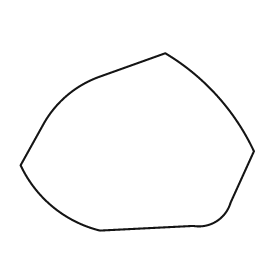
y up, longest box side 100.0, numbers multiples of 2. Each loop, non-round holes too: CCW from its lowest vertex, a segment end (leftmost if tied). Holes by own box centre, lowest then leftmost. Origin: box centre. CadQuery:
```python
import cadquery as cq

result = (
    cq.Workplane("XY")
    .moveTo(-16.0, -38.0)
    .lineTo(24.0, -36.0)
    .threePointArc((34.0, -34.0), (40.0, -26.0))
    .lineTo(50.0, -4.0)
    .threePointArc((34.0, 20.0), (12.0, 38.0))
    .lineTo(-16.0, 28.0)
    .threePointArc((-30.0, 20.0), (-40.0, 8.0))
    .lineTo(-50.0, -10.0)
    .threePointArc((-36.0, -28.0), (-16.0, -38.0))
    .close()
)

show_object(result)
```